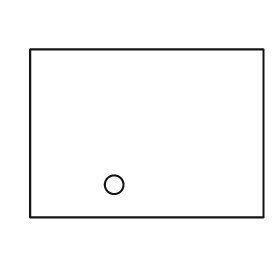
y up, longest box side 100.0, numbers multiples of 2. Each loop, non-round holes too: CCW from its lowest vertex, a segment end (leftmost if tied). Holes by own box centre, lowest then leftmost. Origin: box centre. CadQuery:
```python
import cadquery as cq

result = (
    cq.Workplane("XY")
    .moveTo(-50.0, -36.0)
    .lineTo(50.0, -36.0)
    .lineTo(50.0, 36.0)
    .lineTo(-50.0, 36.0)
    .close()
    .moveTo(-14.0, -22.0)
    .circle(4.0)
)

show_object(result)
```